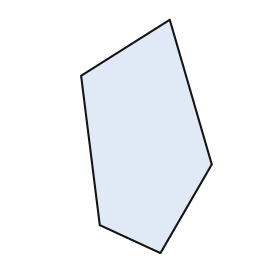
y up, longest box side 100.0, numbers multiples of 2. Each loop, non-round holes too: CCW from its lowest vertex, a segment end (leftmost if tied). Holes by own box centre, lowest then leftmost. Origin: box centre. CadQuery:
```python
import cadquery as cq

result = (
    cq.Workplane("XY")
    .moveTo(6.0, -50.0)
    .lineTo(28.0, -12.0)
    .lineTo(10.0, 50.0)
    .lineTo(-28.0, 26.0)
    .lineTo(-20.0, -38.0)
    .close()
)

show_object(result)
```